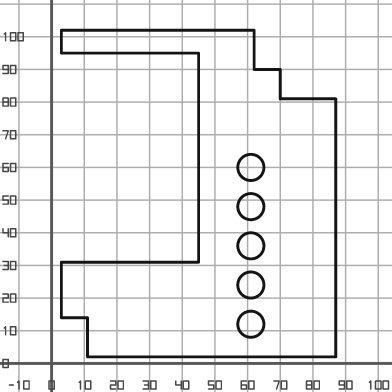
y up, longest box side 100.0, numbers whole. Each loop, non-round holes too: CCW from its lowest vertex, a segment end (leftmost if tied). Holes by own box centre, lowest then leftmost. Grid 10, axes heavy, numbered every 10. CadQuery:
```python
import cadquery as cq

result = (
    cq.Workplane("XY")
    .moveTo(11.0, 2.0)
    .lineTo(87.0, 2.0)
    .lineTo(87.0, 81.0)
    .lineTo(70.0, 81.0)
    .lineTo(70.0, 90.0)
    .lineTo(62.0, 90.0)
    .lineTo(62.0, 102.0)
    .lineTo(3.0, 102.0)
    .lineTo(3.0, 95.0)
    .lineTo(45.0, 95.0)
    .lineTo(45.0, 31.0)
    .lineTo(3.0, 31.0)
    .lineTo(3.0, 14.0)
    .lineTo(11.0, 14.0)
    .close()
    .moveTo(61.0, 12.0)
    .circle(4.0)
    .moveTo(61.0, 24.0)
    .circle(4.0)
    .moveTo(61.0, 36.0)
    .circle(4.0)
    .moveTo(61.0, 48.0)
    .circle(4.0)
    .moveTo(61.0, 60.0)
    .circle(4.0)
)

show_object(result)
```